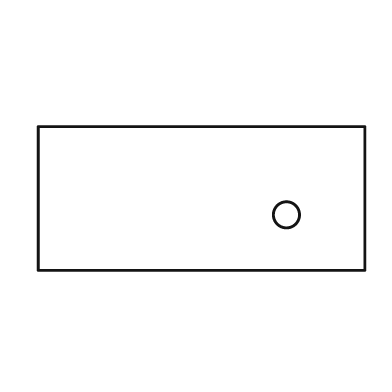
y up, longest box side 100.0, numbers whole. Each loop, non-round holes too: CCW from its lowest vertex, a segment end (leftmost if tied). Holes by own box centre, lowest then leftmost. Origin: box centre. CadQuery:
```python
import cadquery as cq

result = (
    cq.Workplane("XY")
    .moveTo(-50.0, -22.0)
    .lineTo(50.0, -22.0)
    .lineTo(50.0, 22.0)
    .lineTo(-50.0, 22.0)
    .close()
    .moveTo(26.0, -5.0)
    .circle(4.0)
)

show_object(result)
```